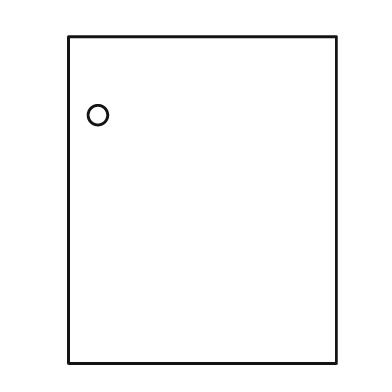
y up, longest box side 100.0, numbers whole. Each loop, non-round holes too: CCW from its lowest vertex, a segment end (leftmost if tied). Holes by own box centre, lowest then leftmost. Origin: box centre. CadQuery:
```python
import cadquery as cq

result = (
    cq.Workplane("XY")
    .moveTo(-41.0, -50.0)
    .lineTo(41.0, -50.0)
    .lineTo(41.0, 50.0)
    .lineTo(-41.0, 50.0)
    .close()
    .moveTo(-32.0, 26.0)
    .circle(3.0)
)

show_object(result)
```